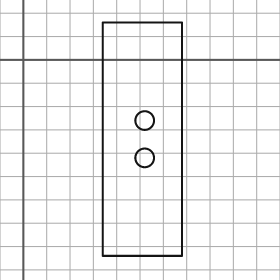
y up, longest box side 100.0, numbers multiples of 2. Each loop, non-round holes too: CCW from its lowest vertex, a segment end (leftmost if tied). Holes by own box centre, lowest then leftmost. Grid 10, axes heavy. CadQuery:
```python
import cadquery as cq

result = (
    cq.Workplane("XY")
    .moveTo(34.0, -84.0)
    .lineTo(68.0, -84.0)
    .lineTo(68.0, 16.0)
    .lineTo(34.0, 16.0)
    .close()
    .moveTo(52.0, -42.0)
    .circle(4.0)
    .moveTo(52.0, -26.0)
    .circle(4.0)
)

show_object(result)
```